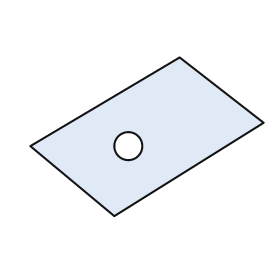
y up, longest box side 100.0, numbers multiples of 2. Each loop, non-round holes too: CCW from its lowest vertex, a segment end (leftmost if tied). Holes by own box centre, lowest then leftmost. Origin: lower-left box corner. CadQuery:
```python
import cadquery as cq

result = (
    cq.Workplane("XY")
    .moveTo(36.0, 0.0)
    .lineTo(100.0, 40.0)
    .lineTo(64.0, 68.0)
    .lineTo(0.0, 30.0)
    .close()
    .moveTo(42.0, 30.0)
    .circle(6.0)
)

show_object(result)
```